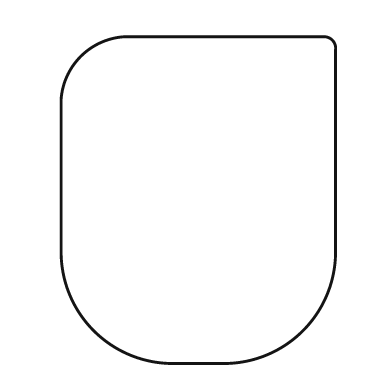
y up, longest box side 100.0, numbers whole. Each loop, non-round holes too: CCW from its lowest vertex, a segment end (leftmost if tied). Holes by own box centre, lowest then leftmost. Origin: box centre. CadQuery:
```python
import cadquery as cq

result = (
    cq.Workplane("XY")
    .moveTo(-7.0, -50.0)
    .lineTo(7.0, -50.0)
    .threePointArc((32.0, -40.0), (42.0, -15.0))
    .lineTo(42.0, 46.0)
    .threePointArc((41.0, 49.0), (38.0, 50.0))
    .lineTo(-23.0, 50.0)
    .threePointArc((-36.0, 44.0), (-42.0, 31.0))
    .lineTo(-42.0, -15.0)
    .threePointArc((-32.0, -40.0), (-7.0, -50.0))
    .close()
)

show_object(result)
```